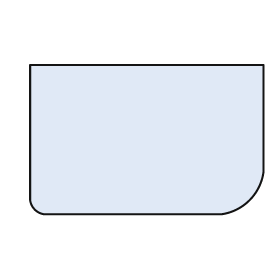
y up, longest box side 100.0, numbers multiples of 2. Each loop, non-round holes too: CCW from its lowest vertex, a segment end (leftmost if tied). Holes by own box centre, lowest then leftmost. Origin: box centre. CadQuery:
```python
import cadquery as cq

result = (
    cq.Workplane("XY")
    .moveTo(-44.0, -32.0)
    .lineTo(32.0, -32.0)
    .threePointArc((44.0, -26.0), (50.0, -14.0))
    .lineTo(50.0, 32.0)
    .lineTo(-50.0, 32.0)
    .lineTo(-50.0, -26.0)
    .threePointArc((-48.0, -30.0), (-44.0, -32.0))
    .close()
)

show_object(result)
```